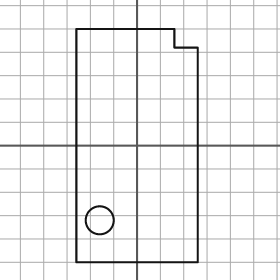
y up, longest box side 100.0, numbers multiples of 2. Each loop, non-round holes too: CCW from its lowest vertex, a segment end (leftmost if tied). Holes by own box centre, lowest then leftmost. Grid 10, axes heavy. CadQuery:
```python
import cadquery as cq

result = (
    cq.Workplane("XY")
    .moveTo(-26.0, -50.0)
    .lineTo(26.0, -50.0)
    .lineTo(26.0, 42.0)
    .lineTo(16.0, 42.0)
    .lineTo(16.0, 50.0)
    .lineTo(-26.0, 50.0)
    .close()
    .moveTo(-16.0, -32.0)
    .circle(6.0)
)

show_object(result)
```